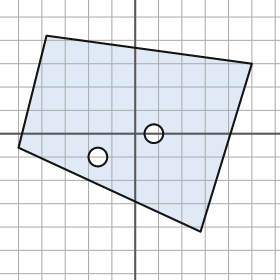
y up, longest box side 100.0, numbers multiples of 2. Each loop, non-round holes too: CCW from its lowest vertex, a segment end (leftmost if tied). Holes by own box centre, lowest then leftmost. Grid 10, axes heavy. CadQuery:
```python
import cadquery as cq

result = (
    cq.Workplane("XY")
    .moveTo(28.0, -42.0)
    .lineTo(50.0, 30.0)
    .lineTo(-38.0, 42.0)
    .lineTo(-50.0, -6.0)
    .close()
    .moveTo(-16.0, -10.0)
    .circle(4.0)
    .moveTo(8.0, 0.0)
    .circle(4.0)
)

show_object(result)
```